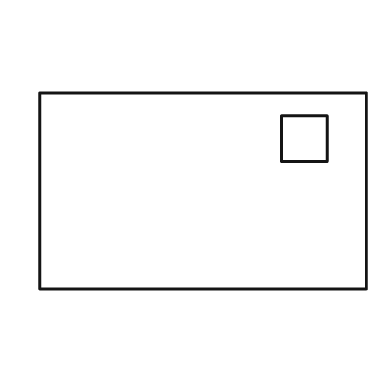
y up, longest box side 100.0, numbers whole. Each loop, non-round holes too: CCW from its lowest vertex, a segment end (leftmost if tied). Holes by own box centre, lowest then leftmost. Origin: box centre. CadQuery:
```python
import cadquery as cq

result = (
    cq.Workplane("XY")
    .moveTo(-50.0, -30.0)
    .lineTo(50.0, -30.0)
    .lineTo(50.0, 30.0)
    .lineTo(-50.0, 30.0)
    .close()
    .moveTo(24.0, 9.0)
    .lineTo(38.0, 9.0)
    .lineTo(38.0, 23.0)
    .lineTo(24.0, 23.0)
    .close()
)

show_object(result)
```